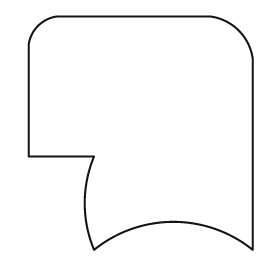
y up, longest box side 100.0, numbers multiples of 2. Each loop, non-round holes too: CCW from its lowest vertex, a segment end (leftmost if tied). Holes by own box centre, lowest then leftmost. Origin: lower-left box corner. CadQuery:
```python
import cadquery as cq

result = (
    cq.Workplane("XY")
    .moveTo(28.0, 0.0)
    .threePointArc((62.0, 12.0), (96.0, 0.0))
    .lineTo(96.0, 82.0)
    .threePointArc((90.0, 94.0), (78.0, 100.0))
    .lineTo(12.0, 100.0)
    .threePointArc((4.0, 96.0), (0.0, 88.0))
    .lineTo(0.0, 40.0)
    .lineTo(28.0, 40.0)
    .threePointArc((24.0, 20.0), (28.0, 0.0))
    .close()
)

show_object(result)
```